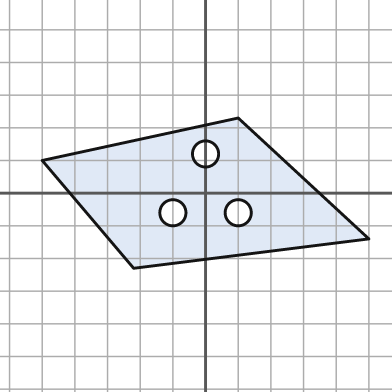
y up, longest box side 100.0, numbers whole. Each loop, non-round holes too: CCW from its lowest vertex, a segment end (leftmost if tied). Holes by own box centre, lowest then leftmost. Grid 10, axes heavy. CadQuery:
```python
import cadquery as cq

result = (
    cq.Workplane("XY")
    .moveTo(-22.0, -23.0)
    .lineTo(50.0, -14.0)
    .lineTo(10.0, 23.0)
    .lineTo(-50.0, 10.0)
    .close()
    .moveTo(-10.0, -6.0)
    .circle(4.0)
    .moveTo(10.0, -6.0)
    .circle(4.0)
    .moveTo(0.0, 12.0)
    .circle(4.0)
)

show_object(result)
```